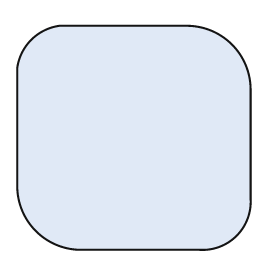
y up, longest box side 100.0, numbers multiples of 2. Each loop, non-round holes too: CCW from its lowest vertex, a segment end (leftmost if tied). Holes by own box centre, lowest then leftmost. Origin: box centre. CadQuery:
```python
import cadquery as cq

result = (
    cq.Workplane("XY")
    .moveTo(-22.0, -48.0)
    .lineTo(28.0, -48.0)
    .threePointArc((44.0, -42.0), (50.0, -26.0))
    .lineTo(50.0, 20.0)
    .threePointArc((42.0, 40.0), (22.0, 48.0))
    .lineTo(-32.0, 48.0)
    .threePointArc((-44.0, 42.0), (-50.0, 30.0))
    .lineTo(-50.0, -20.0)
    .threePointArc((-42.0, -40.0), (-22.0, -48.0))
    .close()
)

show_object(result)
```